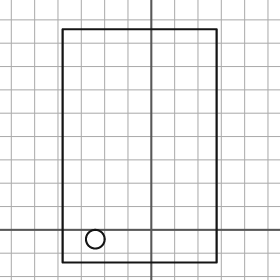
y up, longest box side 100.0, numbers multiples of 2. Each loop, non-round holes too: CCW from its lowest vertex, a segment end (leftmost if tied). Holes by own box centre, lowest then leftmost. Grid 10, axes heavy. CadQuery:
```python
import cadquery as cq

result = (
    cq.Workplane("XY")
    .moveTo(-38.0, -14.0)
    .lineTo(28.0, -14.0)
    .lineTo(28.0, 86.0)
    .lineTo(-38.0, 86.0)
    .close()
    .moveTo(-24.0, -4.0)
    .circle(4.0)
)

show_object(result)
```